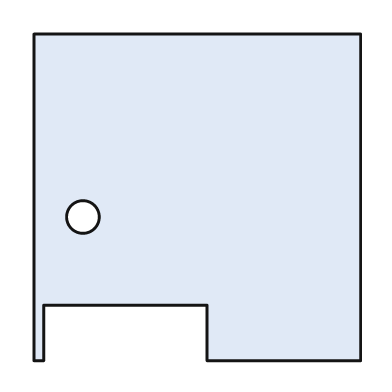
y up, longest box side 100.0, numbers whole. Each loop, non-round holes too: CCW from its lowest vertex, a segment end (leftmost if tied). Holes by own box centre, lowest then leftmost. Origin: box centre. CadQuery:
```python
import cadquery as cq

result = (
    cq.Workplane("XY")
    .moveTo(-50.0, -50.0)
    .lineTo(-47.0, -50.0)
    .lineTo(-47.0, -33.0)
    .lineTo(3.0, -33.0)
    .lineTo(3.0, -50.0)
    .lineTo(50.0, -50.0)
    .lineTo(50.0, 50.0)
    .lineTo(-50.0, 50.0)
    .close()
    .moveTo(-35.0, -6.0)
    .circle(5.0)
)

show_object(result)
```